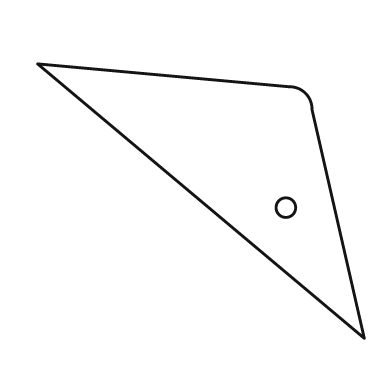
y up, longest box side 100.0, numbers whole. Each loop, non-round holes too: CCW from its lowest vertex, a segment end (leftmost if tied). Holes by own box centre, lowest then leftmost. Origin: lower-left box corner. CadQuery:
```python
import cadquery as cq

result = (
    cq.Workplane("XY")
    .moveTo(100.0, 0.0)
    .lineTo(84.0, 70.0)
    .threePointArc((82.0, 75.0), (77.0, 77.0))
    .lineTo(0.0, 84.0)
    .close()
    .moveTo(76.0, 40.0)
    .circle(3.0)
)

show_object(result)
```